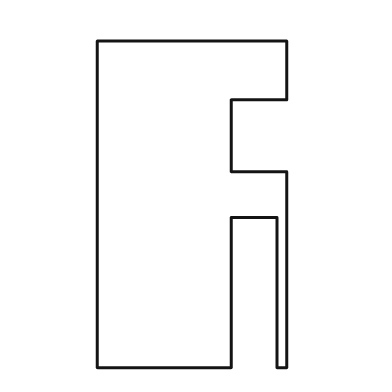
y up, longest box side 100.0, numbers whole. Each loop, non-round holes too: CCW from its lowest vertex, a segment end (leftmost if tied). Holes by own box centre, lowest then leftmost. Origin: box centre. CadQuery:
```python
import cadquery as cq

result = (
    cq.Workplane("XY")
    .moveTo(-29.0, -50.0)
    .lineTo(12.0, -50.0)
    .lineTo(12.0, -4.0)
    .lineTo(26.0, -4.0)
    .lineTo(26.0, -50.0)
    .lineTo(29.0, -50.0)
    .lineTo(29.0, 10.0)
    .lineTo(12.0, 10.0)
    .lineTo(12.0, 32.0)
    .lineTo(29.0, 32.0)
    .lineTo(29.0, 50.0)
    .lineTo(-29.0, 50.0)
    .close()
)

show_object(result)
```